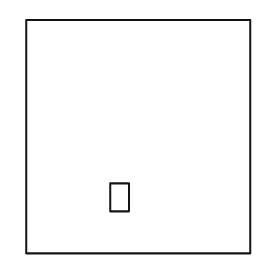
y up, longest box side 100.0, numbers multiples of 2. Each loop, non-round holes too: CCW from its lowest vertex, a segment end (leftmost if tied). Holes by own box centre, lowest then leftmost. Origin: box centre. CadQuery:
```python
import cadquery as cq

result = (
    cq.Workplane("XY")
    .moveTo(-48.0, -50.0)
    .lineTo(48.0, -50.0)
    .lineTo(48.0, 50.0)
    .lineTo(-48.0, 50.0)
    .close()
    .moveTo(-12.0, -32.0)
    .lineTo(-4.0, -32.0)
    .lineTo(-4.0, -20.0)
    .lineTo(-12.0, -20.0)
    .close()
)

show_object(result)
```